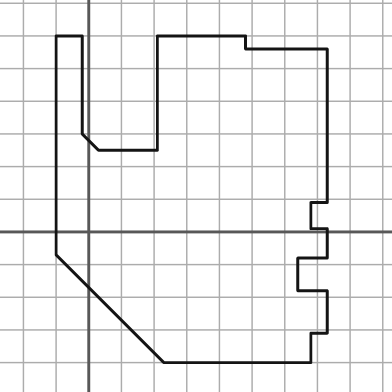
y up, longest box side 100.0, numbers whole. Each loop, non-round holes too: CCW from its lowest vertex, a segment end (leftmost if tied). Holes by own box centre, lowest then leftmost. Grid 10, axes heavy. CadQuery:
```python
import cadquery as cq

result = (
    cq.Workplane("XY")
    .moveTo(23.0, -40.0)
    .lineTo(68.0, -40.0)
    .lineTo(68.0, -31.0)
    .lineTo(73.0, -31.0)
    .lineTo(73.0, -18.0)
    .lineTo(64.0, -18.0)
    .lineTo(64.0, -8.0)
    .lineTo(73.0, -8.0)
    .lineTo(73.0, 1.0)
    .lineTo(68.0, 1.0)
    .lineTo(68.0, 9.0)
    .lineTo(73.0, 9.0)
    .lineTo(73.0, 56.0)
    .lineTo(48.0, 56.0)
    .lineTo(48.0, 60.0)
    .lineTo(21.0, 60.0)
    .lineTo(21.0, 25.0)
    .lineTo(3.0, 25.0)
    .lineTo(-2.0, 30.0)
    .lineTo(-2.0, 60.0)
    .lineTo(-10.0, 60.0)
    .lineTo(-10.0, -7.0)
    .close()
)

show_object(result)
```